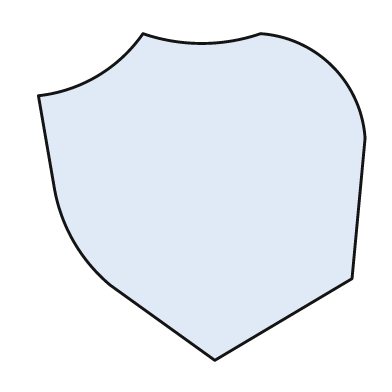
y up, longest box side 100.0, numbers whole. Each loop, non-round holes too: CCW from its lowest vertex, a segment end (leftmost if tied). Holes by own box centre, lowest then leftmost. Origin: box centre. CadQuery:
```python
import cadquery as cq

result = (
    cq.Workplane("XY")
    .moveTo(4.0, -50.0)
    .lineTo(46.0, -25.0)
    .lineTo(50.0, 18.0)
    .threePointArc((40.0, 40.0), (18.0, 50.0))
    .threePointArc((0.0, 47.0), (-18.0, 50.0))
    .threePointArc((-32.0, 37.0), (-50.0, 31.0))
    .lineTo(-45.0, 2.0)
    .threePointArc((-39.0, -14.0), (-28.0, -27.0))
    .close()
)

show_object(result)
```